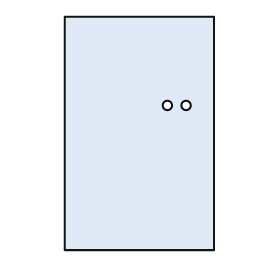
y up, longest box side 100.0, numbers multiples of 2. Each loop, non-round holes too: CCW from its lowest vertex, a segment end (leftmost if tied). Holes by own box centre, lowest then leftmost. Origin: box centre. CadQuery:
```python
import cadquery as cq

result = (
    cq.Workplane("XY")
    .moveTo(-32.0, -50.0)
    .lineTo(32.0, -50.0)
    .lineTo(32.0, 50.0)
    .lineTo(-32.0, 50.0)
    .close()
    .moveTo(12.0, 12.0)
    .circle(2.0)
    .moveTo(20.0, 12.0)
    .circle(2.0)
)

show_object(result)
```